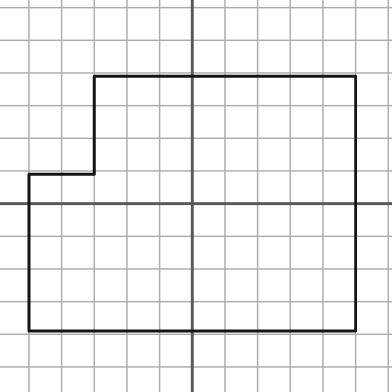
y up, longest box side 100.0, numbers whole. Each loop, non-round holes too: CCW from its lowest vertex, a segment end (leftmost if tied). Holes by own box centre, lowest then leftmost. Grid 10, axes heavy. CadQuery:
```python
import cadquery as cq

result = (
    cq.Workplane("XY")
    .moveTo(-50.0, -39.0)
    .lineTo(50.0, -39.0)
    .lineTo(50.0, 39.0)
    .lineTo(-30.0, 39.0)
    .lineTo(-30.0, 9.0)
    .lineTo(-50.0, 9.0)
    .close()
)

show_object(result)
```